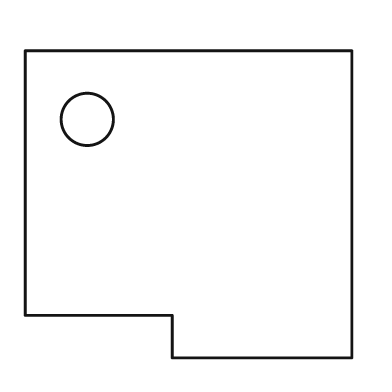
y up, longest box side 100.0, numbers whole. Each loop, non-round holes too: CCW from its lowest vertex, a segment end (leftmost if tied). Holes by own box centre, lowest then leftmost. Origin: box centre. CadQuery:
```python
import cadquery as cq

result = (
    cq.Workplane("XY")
    .moveTo(-5.0, -47.0)
    .lineTo(50.0, -47.0)
    .lineTo(50.0, 47.0)
    .lineTo(-50.0, 47.0)
    .lineTo(-50.0, -34.0)
    .lineTo(-5.0, -34.0)
    .close()
    .moveTo(-31.0, 26.0)
    .circle(8.0)
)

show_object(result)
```